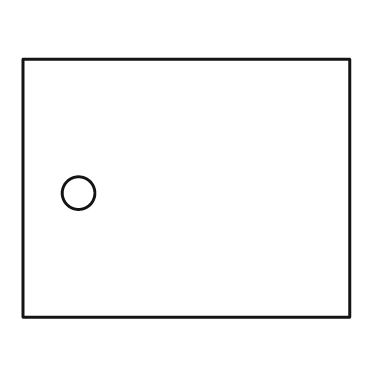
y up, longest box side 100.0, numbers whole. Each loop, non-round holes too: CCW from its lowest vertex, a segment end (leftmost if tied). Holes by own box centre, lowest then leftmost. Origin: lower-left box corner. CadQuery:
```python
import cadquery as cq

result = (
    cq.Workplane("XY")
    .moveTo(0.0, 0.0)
    .lineTo(100.0, 0.0)
    .lineTo(100.0, 79.0)
    .lineTo(0.0, 79.0)
    .close()
    .moveTo(17.0, 38.0)
    .circle(5.0)
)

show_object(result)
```